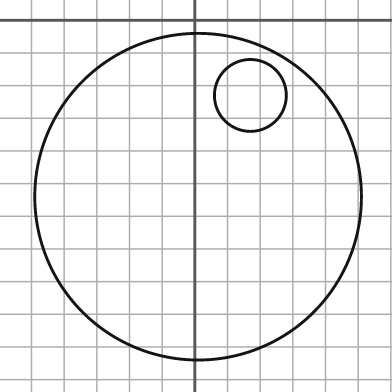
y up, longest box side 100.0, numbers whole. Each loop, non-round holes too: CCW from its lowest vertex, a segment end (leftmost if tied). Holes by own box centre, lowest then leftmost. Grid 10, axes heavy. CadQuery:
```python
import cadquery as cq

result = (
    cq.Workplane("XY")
    .moveTo(1.0, -54.0)
    .circle(50.0)
    .moveTo(17.0, -23.0)
    .circle(11.0)
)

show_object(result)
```